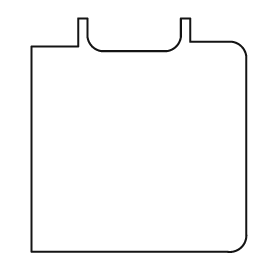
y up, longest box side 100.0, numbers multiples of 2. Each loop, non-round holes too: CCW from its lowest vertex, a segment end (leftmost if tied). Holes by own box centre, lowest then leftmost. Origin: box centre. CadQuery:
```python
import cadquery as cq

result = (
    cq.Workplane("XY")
    .moveTo(-46.0, -50.0)
    .lineTo(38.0, -50.0)
    .threePointArc((44.0, -48.0), (46.0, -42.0))
    .lineTo(46.0, 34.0)
    .threePointArc((44.0, 38.0), (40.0, 40.0))
    .lineTo(22.0, 40.0)
    .lineTo(22.0, 50.0)
    .lineTo(18.0, 50.0)
    .lineTo(18.0, 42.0)
    .threePointArc((16.0, 38.0), (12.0, 36.0))
    .lineTo(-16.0, 36.0)
    .threePointArc((-20.0, 38.0), (-22.0, 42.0))
    .lineTo(-22.0, 50.0)
    .lineTo(-26.0, 50.0)
    .lineTo(-26.0, 38.0)
    .lineTo(-46.0, 38.0)
    .close()
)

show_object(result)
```